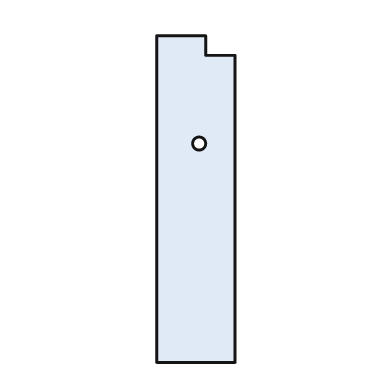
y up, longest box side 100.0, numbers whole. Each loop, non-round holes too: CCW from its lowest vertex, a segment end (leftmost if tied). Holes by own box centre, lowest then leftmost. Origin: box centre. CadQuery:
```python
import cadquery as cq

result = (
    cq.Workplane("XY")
    .moveTo(-12.0, -50.0)
    .lineTo(12.0, -50.0)
    .lineTo(12.0, 44.0)
    .lineTo(3.0, 44.0)
    .lineTo(3.0, 50.0)
    .lineTo(-12.0, 50.0)
    .close()
    .moveTo(1.0, 17.0)
    .circle(2.0)
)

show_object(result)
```